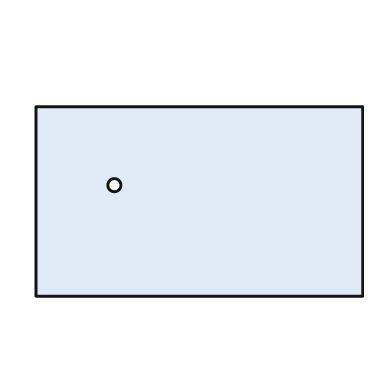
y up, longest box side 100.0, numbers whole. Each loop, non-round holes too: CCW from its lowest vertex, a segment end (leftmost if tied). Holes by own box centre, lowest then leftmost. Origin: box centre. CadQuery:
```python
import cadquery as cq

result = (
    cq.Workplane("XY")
    .moveTo(-50.0, -29.0)
    .lineTo(50.0, -29.0)
    .lineTo(50.0, 29.0)
    .lineTo(-50.0, 29.0)
    .close()
    .moveTo(-26.0, 5.0)
    .circle(2.0)
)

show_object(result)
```